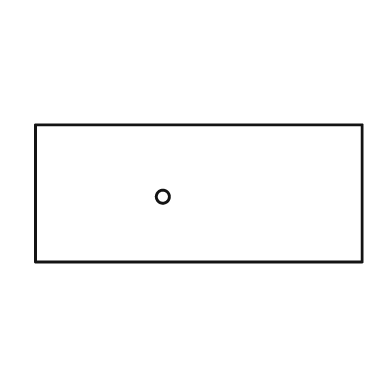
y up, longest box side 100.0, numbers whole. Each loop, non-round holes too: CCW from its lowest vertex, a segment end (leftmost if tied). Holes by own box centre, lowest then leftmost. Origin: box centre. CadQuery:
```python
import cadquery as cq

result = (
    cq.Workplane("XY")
    .moveTo(-50.0, -21.0)
    .lineTo(50.0, -21.0)
    .lineTo(50.0, 21.0)
    .lineTo(-50.0, 21.0)
    .close()
    .moveTo(-11.0, -1.0)
    .circle(2.0)
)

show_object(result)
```